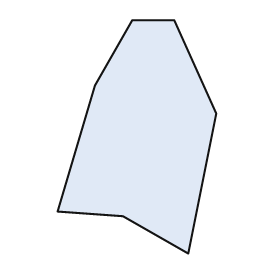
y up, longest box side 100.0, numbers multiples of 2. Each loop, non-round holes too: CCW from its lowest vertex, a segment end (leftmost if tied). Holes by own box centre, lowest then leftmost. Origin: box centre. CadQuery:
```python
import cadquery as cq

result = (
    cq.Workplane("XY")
    .moveTo(22.0, -50.0)
    .lineTo(34.0, 10.0)
    .lineTo(16.0, 50.0)
    .lineTo(-2.0, 50.0)
    .lineTo(-18.0, 22.0)
    .lineTo(-34.0, -32.0)
    .lineTo(-6.0, -34.0)
    .close()
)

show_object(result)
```